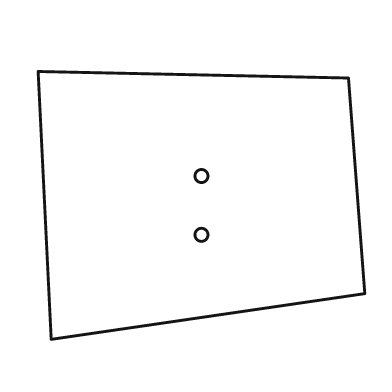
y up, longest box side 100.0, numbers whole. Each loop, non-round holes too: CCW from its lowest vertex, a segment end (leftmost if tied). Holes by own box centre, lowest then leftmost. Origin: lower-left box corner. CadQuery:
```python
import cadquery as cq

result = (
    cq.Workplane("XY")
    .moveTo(4.0, 0.0)
    .lineTo(100.0, 14.0)
    .lineTo(95.0, 80.0)
    .lineTo(0.0, 82.0)
    .close()
    .moveTo(50.0, 32.0)
    .circle(2.0)
    .moveTo(50.0, 50.0)
    .circle(2.0)
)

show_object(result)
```